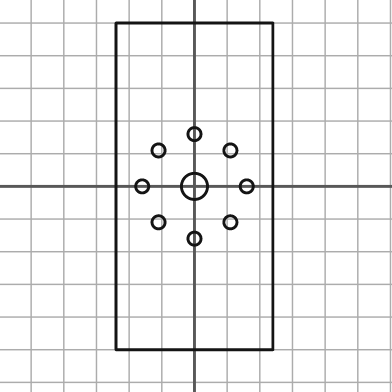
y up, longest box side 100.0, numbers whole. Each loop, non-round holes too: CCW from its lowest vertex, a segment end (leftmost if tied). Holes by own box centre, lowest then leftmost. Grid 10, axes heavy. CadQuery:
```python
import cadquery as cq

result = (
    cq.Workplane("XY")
    .moveTo(-24.0, -50.0)
    .lineTo(24.0, -50.0)
    .lineTo(24.0, 50.0)
    .lineTo(-24.0, 50.0)
    .close()
    .moveTo(0.0, -16.0)
    .circle(2.0)
    .moveTo(-11.0, -11.0)
    .circle(2.0)
    .moveTo(11.0, -11.0)
    .circle(2.0)
    .moveTo(-16.0, 0.0)
    .circle(2.0)
    .moveTo(0.0, 0.0)
    .circle(4.0)
    .moveTo(16.0, 0.0)
    .circle(2.0)
    .moveTo(-11.0, 11.0)
    .circle(2.0)
    .moveTo(11.0, 11.0)
    .circle(2.0)
    .moveTo(0.0, 16.0)
    .circle(2.0)
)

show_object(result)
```